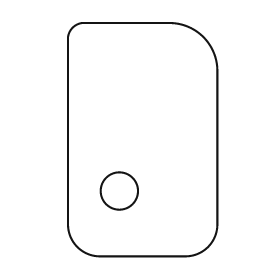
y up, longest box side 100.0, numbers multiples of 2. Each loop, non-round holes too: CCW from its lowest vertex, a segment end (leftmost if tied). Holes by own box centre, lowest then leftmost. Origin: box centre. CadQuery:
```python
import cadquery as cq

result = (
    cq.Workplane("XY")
    .moveTo(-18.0, -50.0)
    .lineTo(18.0, -50.0)
    .threePointArc((28.0, -46.0), (32.0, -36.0))
    .lineTo(32.0, 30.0)
    .threePointArc((26.0, 44.0), (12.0, 50.0))
    .lineTo(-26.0, 50.0)
    .threePointArc((-30.0, 48.0), (-32.0, 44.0))
    .lineTo(-32.0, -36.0)
    .threePointArc((-28.0, -46.0), (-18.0, -50.0))
    .close()
    .moveTo(-10.0, -22.0)
    .circle(8.0)
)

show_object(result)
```